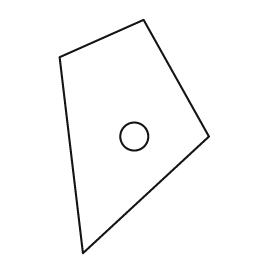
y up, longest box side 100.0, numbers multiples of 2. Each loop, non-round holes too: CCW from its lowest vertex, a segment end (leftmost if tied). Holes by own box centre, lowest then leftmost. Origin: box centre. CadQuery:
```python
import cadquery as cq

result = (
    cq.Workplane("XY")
    .moveTo(-22.0, -50.0)
    .lineTo(32.0, 0.0)
    .lineTo(4.0, 50.0)
    .lineTo(-32.0, 34.0)
    .close()
    .moveTo(0.0, 0.0)
    .circle(6.0)
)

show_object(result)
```